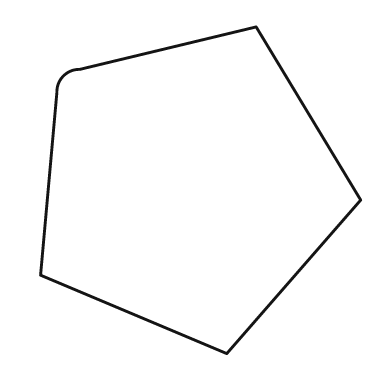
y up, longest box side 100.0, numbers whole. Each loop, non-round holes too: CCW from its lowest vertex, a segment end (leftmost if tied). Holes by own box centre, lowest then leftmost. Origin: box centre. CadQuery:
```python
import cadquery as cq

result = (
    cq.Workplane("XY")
    .moveTo(8.0, -50.0)
    .lineTo(49.0, -3.0)
    .lineTo(17.0, 50.0)
    .lineTo(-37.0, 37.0)
    .threePointArc((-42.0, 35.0), (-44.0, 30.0))
    .lineTo(-49.0, -26.0)
    .close()
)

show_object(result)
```